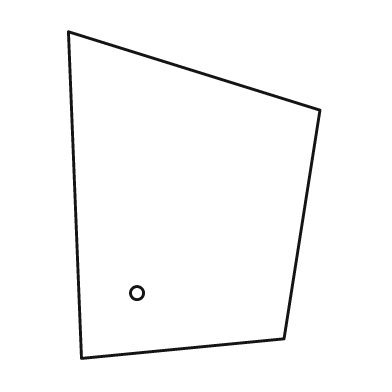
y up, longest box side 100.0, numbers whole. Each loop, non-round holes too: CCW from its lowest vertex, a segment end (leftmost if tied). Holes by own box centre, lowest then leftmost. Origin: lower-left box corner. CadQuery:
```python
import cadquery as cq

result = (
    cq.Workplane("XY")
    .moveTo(4.0, 0.0)
    .lineTo(66.0, 6.0)
    .lineTo(77.0, 76.0)
    .lineTo(0.0, 100.0)
    .close()
    .moveTo(21.0, 20.0)
    .circle(2.0)
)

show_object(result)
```